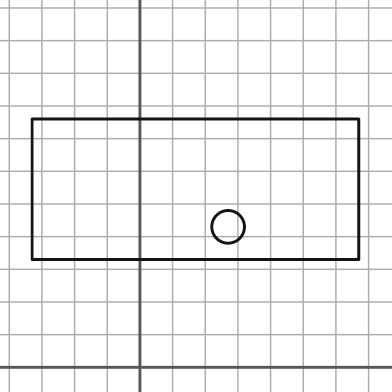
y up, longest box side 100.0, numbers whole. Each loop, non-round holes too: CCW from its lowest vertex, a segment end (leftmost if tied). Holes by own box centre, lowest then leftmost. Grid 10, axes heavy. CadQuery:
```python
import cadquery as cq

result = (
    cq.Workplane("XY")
    .moveTo(-33.0, 33.0)
    .lineTo(67.0, 33.0)
    .lineTo(67.0, 76.0)
    .lineTo(-33.0, 76.0)
    .close()
    .moveTo(27.0, 43.0)
    .circle(5.0)
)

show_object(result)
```